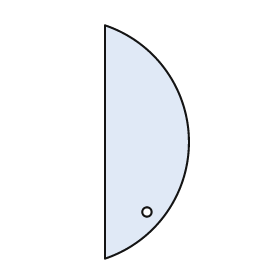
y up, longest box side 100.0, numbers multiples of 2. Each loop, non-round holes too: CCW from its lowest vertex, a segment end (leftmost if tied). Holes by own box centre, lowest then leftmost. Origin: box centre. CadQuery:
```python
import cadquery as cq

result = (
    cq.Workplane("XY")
    .moveTo(-18.0, -50.0)
    .threePointArc((18.0, 0.0), (-18.0, 50.0))
    .close()
    .moveTo(0.0, -30.0)
    .circle(2.0)
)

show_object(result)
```